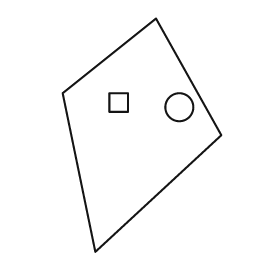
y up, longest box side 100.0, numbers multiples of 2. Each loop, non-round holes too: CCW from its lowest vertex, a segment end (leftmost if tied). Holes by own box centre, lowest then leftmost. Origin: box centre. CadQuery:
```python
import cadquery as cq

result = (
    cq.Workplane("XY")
    .moveTo(-20.0, -50.0)
    .lineTo(34.0, 0.0)
    .lineTo(6.0, 50.0)
    .lineTo(-34.0, 18.0)
    .close()
    .moveTo(16.0, 12.0)
    .circle(6.0)
    .moveTo(-14.0, 10.0)
    .lineTo(-6.0, 10.0)
    .lineTo(-6.0, 18.0)
    .lineTo(-14.0, 18.0)
    .close()
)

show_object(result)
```